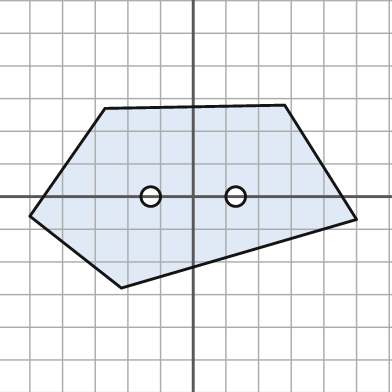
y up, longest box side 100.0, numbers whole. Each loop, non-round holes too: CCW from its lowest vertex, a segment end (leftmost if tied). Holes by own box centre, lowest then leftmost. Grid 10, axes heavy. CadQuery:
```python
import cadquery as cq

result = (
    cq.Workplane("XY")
    .moveTo(-22.0, -28.0)
    .lineTo(50.0, -7.0)
    .lineTo(28.0, 28.0)
    .lineTo(-27.0, 27.0)
    .lineTo(-50.0, -6.0)
    .close()
    .moveTo(-13.0, 0.0)
    .circle(3.0)
    .moveTo(13.0, 0.0)
    .circle(3.0)
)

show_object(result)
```